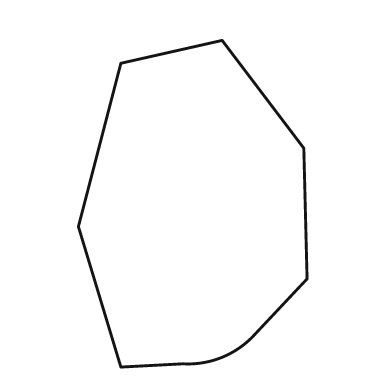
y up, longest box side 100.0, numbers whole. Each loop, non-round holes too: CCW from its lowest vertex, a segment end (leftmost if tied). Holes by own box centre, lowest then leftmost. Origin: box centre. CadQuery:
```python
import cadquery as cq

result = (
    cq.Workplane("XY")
    .moveTo(-22.0, -50.0)
    .lineTo(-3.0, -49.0)
    .threePointArc((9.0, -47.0), (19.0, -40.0))
    .lineTo(35.0, -23.0)
    .lineTo(34.0, 17.0)
    .lineTo(9.0, 50.0)
    .lineTo(-22.0, 43.0)
    .lineTo(-35.0, -7.0)
    .close()
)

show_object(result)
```